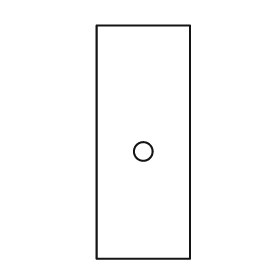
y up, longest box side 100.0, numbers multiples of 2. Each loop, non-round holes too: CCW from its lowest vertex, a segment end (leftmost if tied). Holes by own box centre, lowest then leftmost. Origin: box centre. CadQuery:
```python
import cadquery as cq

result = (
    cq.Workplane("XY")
    .moveTo(-20.0, -50.0)
    .lineTo(20.0, -50.0)
    .lineTo(20.0, 50.0)
    .lineTo(-20.0, 50.0)
    .close()
    .moveTo(0.0, -4.0)
    .circle(4.0)
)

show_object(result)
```